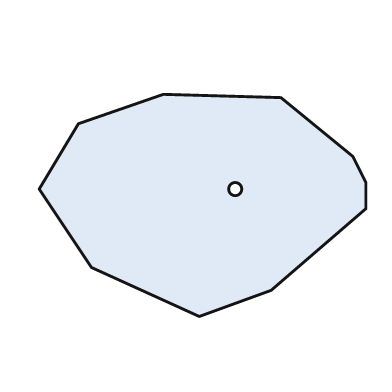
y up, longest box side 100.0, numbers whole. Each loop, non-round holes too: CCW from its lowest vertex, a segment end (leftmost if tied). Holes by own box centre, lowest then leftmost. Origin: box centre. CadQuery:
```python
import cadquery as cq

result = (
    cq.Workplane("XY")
    .moveTo(-1.0, -34.0)
    .lineTo(21.0, -26.0)
    .lineTo(50.0, -1.0)
    .lineTo(50.0, 7.0)
    .lineTo(46.0, 15.0)
    .lineTo(24.0, 33.0)
    .lineTo(-12.0, 34.0)
    .lineTo(-38.0, 25.0)
    .lineTo(-50.0, 5.0)
    .lineTo(-34.0, -19.0)
    .close()
    .moveTo(10.0, 5.0)
    .circle(2.0)
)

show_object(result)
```